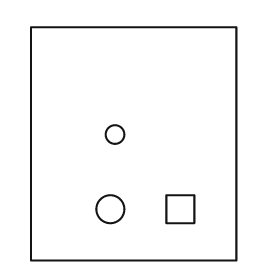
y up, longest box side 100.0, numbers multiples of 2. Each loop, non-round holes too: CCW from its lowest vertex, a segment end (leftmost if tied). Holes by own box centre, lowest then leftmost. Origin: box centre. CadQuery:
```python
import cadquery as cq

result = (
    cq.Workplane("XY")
    .moveTo(-44.0, -50.0)
    .lineTo(44.0, -50.0)
    .lineTo(44.0, 50.0)
    .lineTo(-44.0, 50.0)
    .close()
    .moveTo(-10.0, -28.0)
    .circle(6.0)
    .moveTo(14.0, -34.0)
    .lineTo(26.0, -34.0)
    .lineTo(26.0, -22.0)
    .lineTo(14.0, -22.0)
    .close()
    .moveTo(-8.0, 4.0)
    .circle(4.0)
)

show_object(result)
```